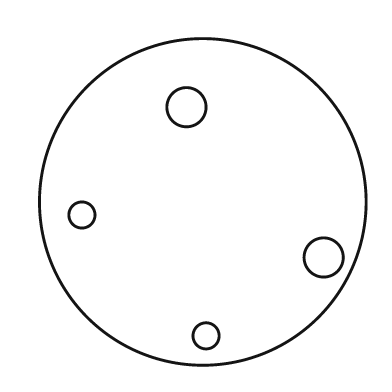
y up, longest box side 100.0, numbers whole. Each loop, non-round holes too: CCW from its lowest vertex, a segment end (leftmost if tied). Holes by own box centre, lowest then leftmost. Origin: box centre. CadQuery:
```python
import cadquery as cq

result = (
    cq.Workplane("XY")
    .moveTo(0.0, 0.0)
    .circle(50.0)
    .moveTo(1.0, -41.0)
    .circle(4.0)
    .moveTo(37.0, -17.0)
    .circle(6.0)
    .moveTo(-37.0, -4.0)
    .circle(4.0)
    .moveTo(-5.0, 29.0)
    .circle(6.0)
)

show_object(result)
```